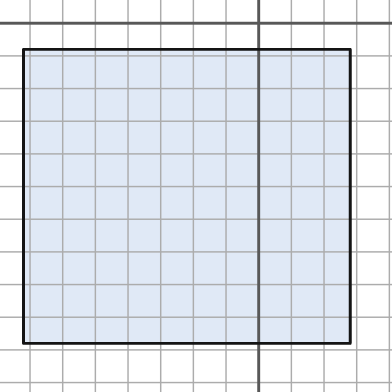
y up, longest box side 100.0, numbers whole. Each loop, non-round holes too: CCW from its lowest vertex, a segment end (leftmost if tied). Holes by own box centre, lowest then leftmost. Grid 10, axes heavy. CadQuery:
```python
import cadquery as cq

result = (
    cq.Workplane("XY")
    .moveTo(-72.0, -98.0)
    .lineTo(28.0, -98.0)
    .lineTo(28.0, -8.0)
    .lineTo(-72.0, -8.0)
    .close()
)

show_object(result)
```